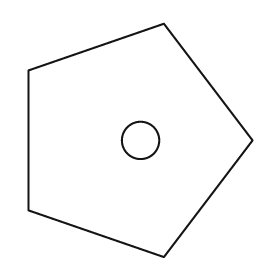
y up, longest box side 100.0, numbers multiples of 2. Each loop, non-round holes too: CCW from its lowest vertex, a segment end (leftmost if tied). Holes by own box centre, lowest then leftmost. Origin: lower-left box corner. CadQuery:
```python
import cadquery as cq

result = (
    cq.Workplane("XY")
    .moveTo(58.0, 0.0)
    .lineTo(96.0, 50.0)
    .lineTo(58.0, 100.0)
    .lineTo(0.0, 80.0)
    .lineTo(0.0, 20.0)
    .close()
    .moveTo(48.0, 50.0)
    .circle(8.0)
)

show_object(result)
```